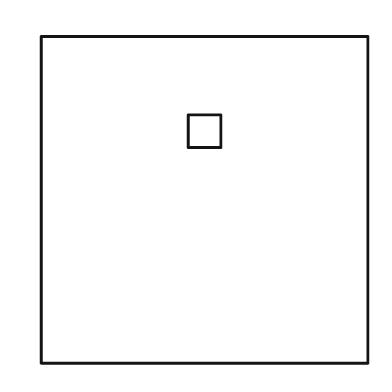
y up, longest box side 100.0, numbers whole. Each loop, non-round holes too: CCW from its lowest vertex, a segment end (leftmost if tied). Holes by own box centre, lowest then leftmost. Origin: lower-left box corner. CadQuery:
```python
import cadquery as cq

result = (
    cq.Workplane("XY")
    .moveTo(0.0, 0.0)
    .lineTo(100.0, 0.0)
    .lineTo(100.0, 100.0)
    .lineTo(0.0, 100.0)
    .close()
    .moveTo(45.0, 66.0)
    .lineTo(55.0, 66.0)
    .lineTo(55.0, 76.0)
    .lineTo(45.0, 76.0)
    .close()
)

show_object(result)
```